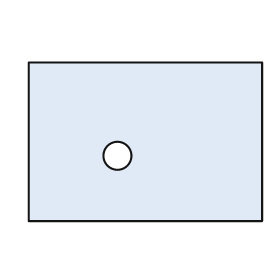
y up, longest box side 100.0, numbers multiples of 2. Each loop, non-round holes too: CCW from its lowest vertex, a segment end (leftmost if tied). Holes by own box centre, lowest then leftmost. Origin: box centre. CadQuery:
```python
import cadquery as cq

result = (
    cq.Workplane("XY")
    .moveTo(-50.0, -34.0)
    .lineTo(50.0, -34.0)
    .lineTo(50.0, 34.0)
    .lineTo(-50.0, 34.0)
    .close()
    .moveTo(-12.0, -6.0)
    .circle(6.0)
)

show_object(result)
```